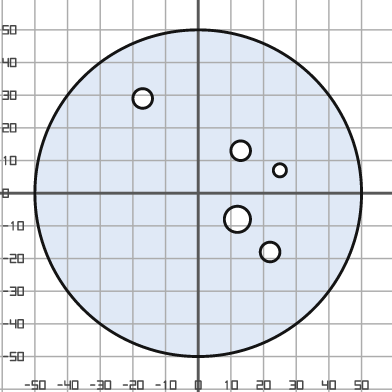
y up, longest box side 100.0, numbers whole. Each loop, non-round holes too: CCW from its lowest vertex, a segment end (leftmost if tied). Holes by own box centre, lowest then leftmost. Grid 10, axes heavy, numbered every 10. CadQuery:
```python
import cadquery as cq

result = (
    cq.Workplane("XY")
    .moveTo(0.0, 0.0)
    .circle(50.0)
    .moveTo(22.0, -18.0)
    .circle(3.0)
    .moveTo(12.0, -8.0)
    .circle(4.0)
    .moveTo(25.0, 7.0)
    .circle(2.0)
    .moveTo(13.0, 13.0)
    .circle(3.0)
    .moveTo(-17.0, 29.0)
    .circle(3.0)
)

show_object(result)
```